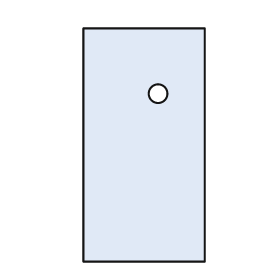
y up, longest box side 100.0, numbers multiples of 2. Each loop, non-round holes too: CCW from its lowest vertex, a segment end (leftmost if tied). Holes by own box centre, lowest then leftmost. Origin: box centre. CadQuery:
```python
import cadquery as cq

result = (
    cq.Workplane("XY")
    .moveTo(-26.0, -50.0)
    .lineTo(26.0, -50.0)
    .lineTo(26.0, 50.0)
    .lineTo(-26.0, 50.0)
    .close()
    .moveTo(6.0, 22.0)
    .circle(4.0)
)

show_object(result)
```